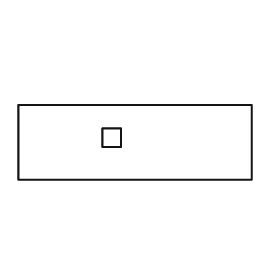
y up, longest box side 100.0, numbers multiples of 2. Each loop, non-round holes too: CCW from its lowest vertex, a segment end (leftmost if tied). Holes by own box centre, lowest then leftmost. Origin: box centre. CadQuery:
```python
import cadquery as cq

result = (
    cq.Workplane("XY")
    .moveTo(-50.0, -16.0)
    .lineTo(50.0, -16.0)
    .lineTo(50.0, 16.0)
    .lineTo(-50.0, 16.0)
    .close()
    .moveTo(-14.0, -2.0)
    .lineTo(-6.0, -2.0)
    .lineTo(-6.0, 6.0)
    .lineTo(-14.0, 6.0)
    .close()
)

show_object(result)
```